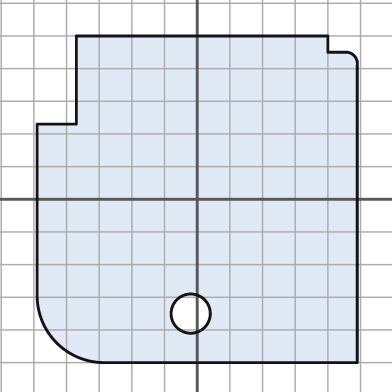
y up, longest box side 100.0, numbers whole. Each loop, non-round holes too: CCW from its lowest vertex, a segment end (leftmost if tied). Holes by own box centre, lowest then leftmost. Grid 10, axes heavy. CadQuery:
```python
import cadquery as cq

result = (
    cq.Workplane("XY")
    .moveTo(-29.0, -50.0)
    .lineTo(49.0, -50.0)
    .lineTo(49.0, 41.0)
    .threePointArc((48.0, 44.0), (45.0, 45.0))
    .lineTo(40.0, 45.0)
    .lineTo(40.0, 50.0)
    .lineTo(-37.0, 50.0)
    .lineTo(-37.0, 23.0)
    .lineTo(-49.0, 23.0)
    .lineTo(-49.0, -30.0)
    .threePointArc((-43.0, -44.0), (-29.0, -50.0))
    .close()
    .moveTo(-2.0, -35.0)
    .circle(6.0)
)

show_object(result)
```